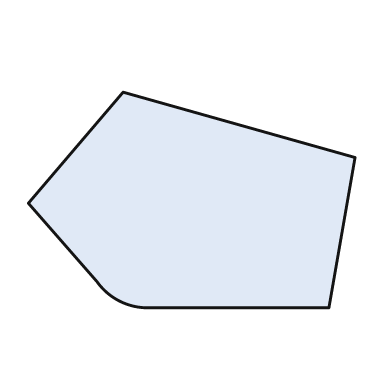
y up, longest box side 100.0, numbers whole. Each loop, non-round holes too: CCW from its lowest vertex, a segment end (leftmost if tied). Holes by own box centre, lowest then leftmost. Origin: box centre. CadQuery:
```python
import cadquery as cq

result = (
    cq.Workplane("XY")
    .moveTo(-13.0, -33.0)
    .lineTo(42.0, -33.0)
    .lineTo(50.0, 13.0)
    .lineTo(-21.0, 33.0)
    .lineTo(-50.0, -1.0)
    .lineTo(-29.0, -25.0)
    .threePointArc((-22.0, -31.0), (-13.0, -33.0))
    .close()
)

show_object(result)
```